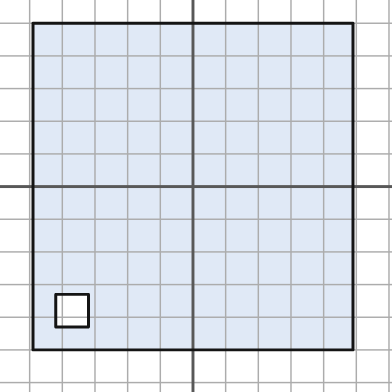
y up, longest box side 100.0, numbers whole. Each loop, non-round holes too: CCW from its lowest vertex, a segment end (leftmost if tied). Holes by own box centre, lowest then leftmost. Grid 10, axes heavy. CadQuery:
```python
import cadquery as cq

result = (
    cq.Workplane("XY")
    .moveTo(-49.0, -50.0)
    .lineTo(49.0, -50.0)
    .lineTo(49.0, 50.0)
    .lineTo(-49.0, 50.0)
    .close()
    .moveTo(-42.0, -43.0)
    .lineTo(-32.0, -43.0)
    .lineTo(-32.0, -33.0)
    .lineTo(-42.0, -33.0)
    .close()
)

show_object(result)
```